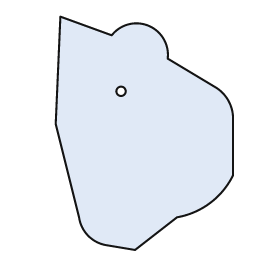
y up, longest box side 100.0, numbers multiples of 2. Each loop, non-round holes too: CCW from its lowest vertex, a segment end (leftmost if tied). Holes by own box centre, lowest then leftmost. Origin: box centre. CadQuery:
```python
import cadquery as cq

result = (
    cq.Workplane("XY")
    .moveTo(-4.0, -50.0)
    .lineTo(14.0, -36.0)
    .threePointArc((28.0, -30.0), (38.0, -18.0))
    .lineTo(38.0, 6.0)
    .threePointArc((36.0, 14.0), (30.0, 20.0))
    .lineTo(10.0, 32.0)
    .threePointArc((2.0, 46.0), (-14.0, 42.0))
    .lineTo(-36.0, 50.0)
    .lineTo(-38.0, 4.0)
    .lineTo(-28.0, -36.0)
    .threePointArc((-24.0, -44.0), (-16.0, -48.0))
    .close()
    .moveTo(-10.0, 18.0)
    .circle(2.0)
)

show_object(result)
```